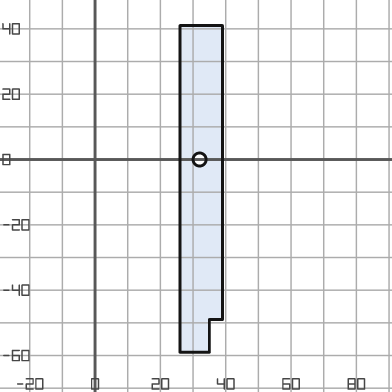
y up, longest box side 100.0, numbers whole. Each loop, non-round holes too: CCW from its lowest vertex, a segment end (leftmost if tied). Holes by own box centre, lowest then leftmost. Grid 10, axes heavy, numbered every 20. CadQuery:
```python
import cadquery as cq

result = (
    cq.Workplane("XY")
    .moveTo(26.0, -59.0)
    .lineTo(35.0, -59.0)
    .lineTo(35.0, -49.0)
    .lineTo(39.0, -49.0)
    .lineTo(39.0, 41.0)
    .lineTo(26.0, 41.0)
    .close()
    .moveTo(32.0, 0.0)
    .circle(2.0)
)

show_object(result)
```